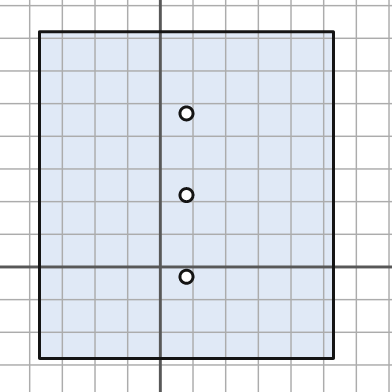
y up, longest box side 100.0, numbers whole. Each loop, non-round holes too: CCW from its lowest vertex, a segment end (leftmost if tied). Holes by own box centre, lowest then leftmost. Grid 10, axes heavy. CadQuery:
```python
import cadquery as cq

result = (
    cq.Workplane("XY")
    .moveTo(-37.0, -28.0)
    .lineTo(53.0, -28.0)
    .lineTo(53.0, 72.0)
    .lineTo(-37.0, 72.0)
    .close()
    .moveTo(8.0, -3.0)
    .circle(2.0)
    .moveTo(8.0, 22.0)
    .circle(2.0)
    .moveTo(8.0, 47.0)
    .circle(2.0)
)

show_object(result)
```